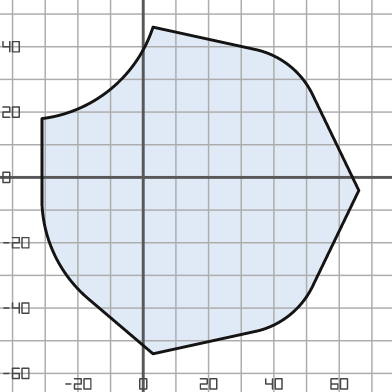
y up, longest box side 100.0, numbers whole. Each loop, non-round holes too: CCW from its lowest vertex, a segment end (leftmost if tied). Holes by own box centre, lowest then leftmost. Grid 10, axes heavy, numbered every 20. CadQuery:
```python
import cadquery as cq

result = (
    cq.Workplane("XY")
    .moveTo(3.0, -54.0)
    .lineTo(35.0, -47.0)
    .threePointArc((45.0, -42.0), (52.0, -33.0))
    .lineTo(66.0, -4.0)
    .lineTo(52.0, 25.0)
    .threePointArc((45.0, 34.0), (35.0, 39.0))
    .lineTo(3.0, 46.0)
    .threePointArc((-10.0, 27.0), (-31.0, 18.0))
    .lineTo(-31.0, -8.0)
    .threePointArc((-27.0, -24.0), (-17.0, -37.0))
    .close()
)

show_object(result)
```